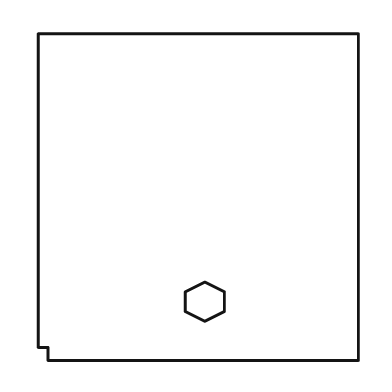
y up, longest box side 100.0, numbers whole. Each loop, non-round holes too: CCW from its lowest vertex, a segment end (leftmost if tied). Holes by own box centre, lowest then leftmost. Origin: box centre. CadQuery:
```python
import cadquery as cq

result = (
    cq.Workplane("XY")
    .moveTo(-46.0, -50.0)
    .lineTo(49.0, -50.0)
    .lineTo(49.0, 50.0)
    .lineTo(-49.0, 50.0)
    .lineTo(-49.0, -46.0)
    .lineTo(-46.0, -46.0)
    .close()
    .moveTo(2.0, -38.0)
    .lineTo(8.0, -35.0)
    .lineTo(8.0, -29.0)
    .lineTo(2.0, -26.0)
    .lineTo(-4.0, -29.0)
    .lineTo(-4.0, -35.0)
    .close()
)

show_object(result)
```